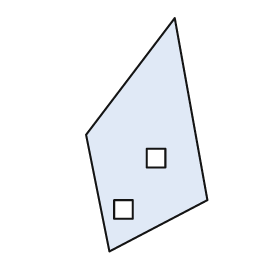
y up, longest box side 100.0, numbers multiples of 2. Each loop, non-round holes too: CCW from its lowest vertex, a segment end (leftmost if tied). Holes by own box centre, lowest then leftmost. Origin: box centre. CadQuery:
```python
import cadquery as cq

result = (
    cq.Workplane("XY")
    .moveTo(-16.0, -50.0)
    .lineTo(26.0, -28.0)
    .lineTo(12.0, 50.0)
    .lineTo(-26.0, 0.0)
    .close()
    .moveTo(-14.0, -36.0)
    .lineTo(-6.0, -36.0)
    .lineTo(-6.0, -28.0)
    .lineTo(-14.0, -28.0)
    .close()
    .moveTo(0.0, -14.0)
    .lineTo(8.0, -14.0)
    .lineTo(8.0, -6.0)
    .lineTo(0.0, -6.0)
    .close()
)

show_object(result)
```